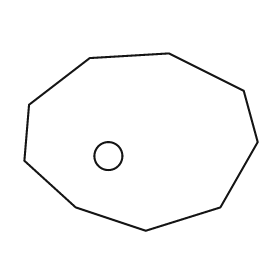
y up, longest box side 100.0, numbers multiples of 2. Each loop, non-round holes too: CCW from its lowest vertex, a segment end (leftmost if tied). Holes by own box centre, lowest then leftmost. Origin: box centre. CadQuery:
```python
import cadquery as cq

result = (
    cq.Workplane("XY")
    .moveTo(2.0, -38.0)
    .lineTo(34.0, -28.0)
    .lineTo(50.0, 0.0)
    .lineTo(44.0, 22.0)
    .lineTo(12.0, 38.0)
    .lineTo(-22.0, 36.0)
    .lineTo(-48.0, 16.0)
    .lineTo(-50.0, -8.0)
    .lineTo(-28.0, -28.0)
    .close()
    .moveTo(-14.0, -6.0)
    .circle(6.0)
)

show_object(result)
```